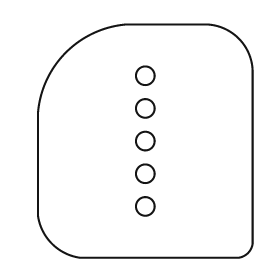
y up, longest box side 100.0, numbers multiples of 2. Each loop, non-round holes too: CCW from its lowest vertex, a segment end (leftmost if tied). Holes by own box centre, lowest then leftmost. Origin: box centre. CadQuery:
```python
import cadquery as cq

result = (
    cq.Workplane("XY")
    .moveTo(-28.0, -50.0)
    .lineTo(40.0, -50.0)
    .threePointArc((44.0, -48.0), (46.0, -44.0))
    .lineTo(46.0, 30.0)
    .threePointArc((40.0, 44.0), (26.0, 50.0))
    .lineTo(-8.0, 50.0)
    .threePointArc((-34.0, 38.0), (-46.0, 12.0))
    .lineTo(-46.0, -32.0)
    .threePointArc((-40.0, -44.0), (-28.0, -50.0))
    .close()
    .moveTo(0.0, -28.0)
    .circle(4.0)
    .moveTo(0.0, -14.0)
    .circle(4.0)
    .moveTo(0.0, 0.0)
    .circle(4.0)
    .moveTo(0.0, 14.0)
    .circle(4.0)
    .moveTo(0.0, 28.0)
    .circle(4.0)
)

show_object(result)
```